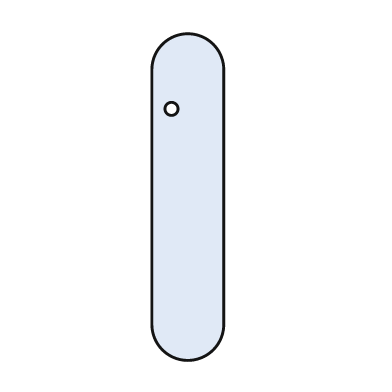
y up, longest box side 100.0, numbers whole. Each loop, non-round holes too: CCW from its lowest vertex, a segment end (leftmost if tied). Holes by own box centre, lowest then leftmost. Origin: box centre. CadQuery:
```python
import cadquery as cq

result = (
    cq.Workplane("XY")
    .moveTo(-11.0, -39.0)
    .threePointArc((0.0, -50.0), (11.0, -39.0))
    .lineTo(11.0, 39.0)
    .threePointArc((0.0, 50.0), (-11.0, 39.0))
    .close()
    .moveTo(-5.0, 27.0)
    .circle(2.0)
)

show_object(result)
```